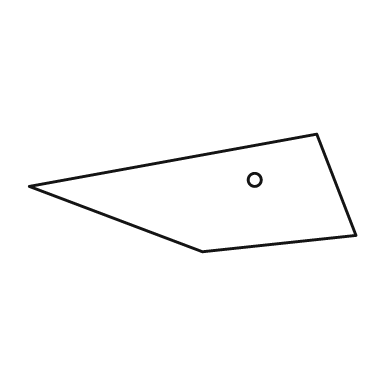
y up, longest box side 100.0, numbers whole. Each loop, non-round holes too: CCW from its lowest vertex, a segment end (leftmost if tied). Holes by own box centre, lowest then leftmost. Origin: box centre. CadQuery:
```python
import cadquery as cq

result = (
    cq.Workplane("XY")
    .moveTo(3.0, -18.0)
    .lineTo(50.0, -13.0)
    .lineTo(38.0, 18.0)
    .lineTo(-50.0, 2.0)
    .close()
    .moveTo(19.0, 4.0)
    .circle(2.0)
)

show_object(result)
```